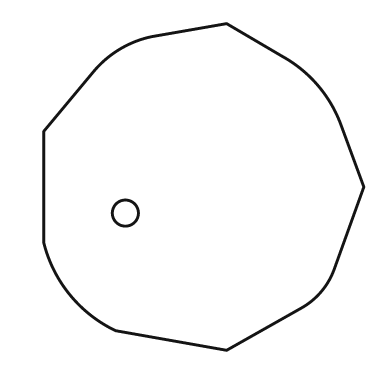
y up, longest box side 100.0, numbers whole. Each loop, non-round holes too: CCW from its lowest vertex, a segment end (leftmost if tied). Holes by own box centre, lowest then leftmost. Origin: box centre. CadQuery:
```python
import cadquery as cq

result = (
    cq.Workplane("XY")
    .moveTo(7.0, -50.0)
    .lineTo(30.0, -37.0)
    .threePointArc((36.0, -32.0), (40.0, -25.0))
    .lineTo(49.0, 0.0)
    .lineTo(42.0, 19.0)
    .threePointArc((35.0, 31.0), (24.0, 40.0))
    .lineTo(7.0, 50.0)
    .lineTo(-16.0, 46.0)
    .threePointArc((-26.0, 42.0), (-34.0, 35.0))
    .lineTo(-49.0, 17.0)
    .lineTo(-49.0, -17.0)
    .threePointArc((-41.0, -33.0), (-27.0, -44.0))
    .close()
    .moveTo(-24.0, -8.0)
    .circle(4.0)
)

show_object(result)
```